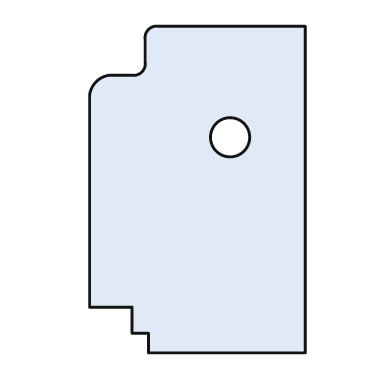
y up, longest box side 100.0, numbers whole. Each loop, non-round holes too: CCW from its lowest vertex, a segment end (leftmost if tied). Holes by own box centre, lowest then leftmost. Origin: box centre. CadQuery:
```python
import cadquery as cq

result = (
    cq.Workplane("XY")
    .moveTo(-15.0, -50.0)
    .lineTo(33.0, -50.0)
    .lineTo(33.0, 50.0)
    .lineTo(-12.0, 50.0)
    .threePointArc((-15.0, 49.0), (-16.0, 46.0))
    .lineTo(-16.0, 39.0)
    .threePointArc((-17.0, 36.0), (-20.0, 35.0))
    .lineTo(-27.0, 35.0)
    .threePointArc((-31.0, 33.0), (-33.0, 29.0))
    .lineTo(-33.0, -36.0)
    .lineTo(-20.0, -36.0)
    .lineTo(-20.0, -44.0)
    .lineTo(-15.0, -44.0)
    .close()
    .moveTo(10.0, 16.0)
    .circle(6.0)
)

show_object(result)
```